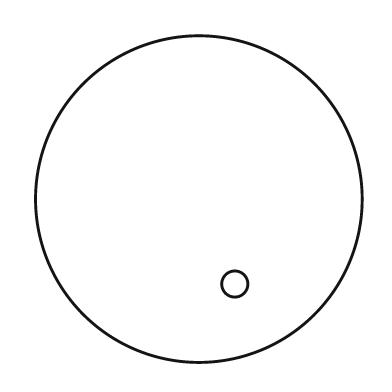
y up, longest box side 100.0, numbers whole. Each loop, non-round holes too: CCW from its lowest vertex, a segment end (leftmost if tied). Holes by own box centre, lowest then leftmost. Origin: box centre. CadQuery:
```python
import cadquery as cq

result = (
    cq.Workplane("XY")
    .moveTo(0.0, 0.0)
    .circle(50.0)
    .moveTo(11.0, -26.0)
    .circle(4.0)
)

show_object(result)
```